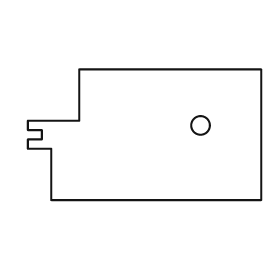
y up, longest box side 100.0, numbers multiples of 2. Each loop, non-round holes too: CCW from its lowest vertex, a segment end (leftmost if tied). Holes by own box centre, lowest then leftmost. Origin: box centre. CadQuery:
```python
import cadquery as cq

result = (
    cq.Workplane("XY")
    .moveTo(-40.0, -28.0)
    .lineTo(50.0, -28.0)
    .lineTo(50.0, 28.0)
    .lineTo(-28.0, 28.0)
    .lineTo(-28.0, 6.0)
    .lineTo(-50.0, 6.0)
    .lineTo(-50.0, 2.0)
    .lineTo(-44.0, 2.0)
    .lineTo(-44.0, -2.0)
    .lineTo(-50.0, -2.0)
    .lineTo(-50.0, -6.0)
    .lineTo(-40.0, -6.0)
    .close()
    .moveTo(24.0, 4.0)
    .circle(4.0)
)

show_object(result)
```